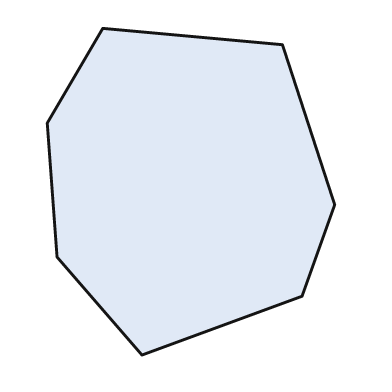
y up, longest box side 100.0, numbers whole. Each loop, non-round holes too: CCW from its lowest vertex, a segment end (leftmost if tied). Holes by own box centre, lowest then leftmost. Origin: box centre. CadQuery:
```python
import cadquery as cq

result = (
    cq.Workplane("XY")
    .moveTo(-15.0, -50.0)
    .lineTo(34.0, -32.0)
    .lineTo(44.0, -4.0)
    .lineTo(28.0, 45.0)
    .lineTo(-27.0, 50.0)
    .lineTo(-44.0, 21.0)
    .lineTo(-41.0, -20.0)
    .close()
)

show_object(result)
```